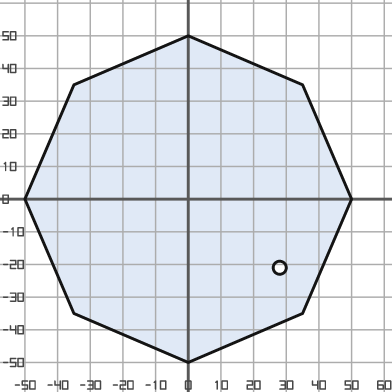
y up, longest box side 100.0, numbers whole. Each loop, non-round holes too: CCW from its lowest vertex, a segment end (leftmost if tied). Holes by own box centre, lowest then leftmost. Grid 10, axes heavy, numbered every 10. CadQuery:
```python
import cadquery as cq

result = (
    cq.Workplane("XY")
    .moveTo(0.0, -50.0)
    .lineTo(35.0, -35.0)
    .lineTo(50.0, 0.0)
    .lineTo(35.0, 35.0)
    .lineTo(0.0, 50.0)
    .lineTo(-35.0, 35.0)
    .lineTo(-50.0, 0.0)
    .lineTo(-35.0, -35.0)
    .close()
    .moveTo(28.0, -21.0)
    .circle(2.0)
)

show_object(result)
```